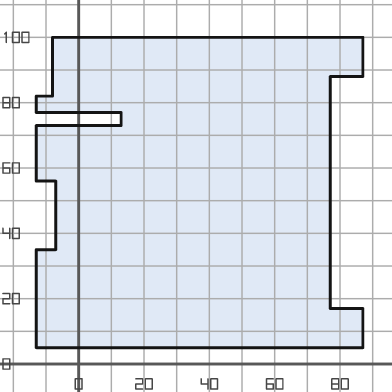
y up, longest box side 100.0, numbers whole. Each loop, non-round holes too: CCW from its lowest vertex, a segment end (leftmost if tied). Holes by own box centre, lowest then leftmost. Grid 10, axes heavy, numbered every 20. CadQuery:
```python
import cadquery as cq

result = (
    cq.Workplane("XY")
    .moveTo(-13.0, 5.0)
    .lineTo(87.0, 5.0)
    .lineTo(87.0, 17.0)
    .lineTo(77.0, 17.0)
    .lineTo(77.0, 88.0)
    .lineTo(87.0, 88.0)
    .lineTo(87.0, 100.0)
    .lineTo(-8.0, 100.0)
    .lineTo(-8.0, 82.0)
    .lineTo(-13.0, 82.0)
    .lineTo(-13.0, 77.0)
    .lineTo(13.0, 77.0)
    .lineTo(13.0, 73.0)
    .lineTo(-13.0, 73.0)
    .lineTo(-13.0, 56.0)
    .lineTo(-7.0, 56.0)
    .lineTo(-7.0, 35.0)
    .lineTo(-13.0, 35.0)
    .close()
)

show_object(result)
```